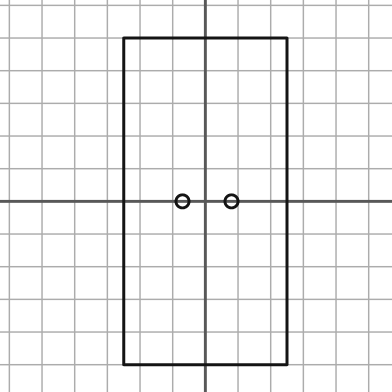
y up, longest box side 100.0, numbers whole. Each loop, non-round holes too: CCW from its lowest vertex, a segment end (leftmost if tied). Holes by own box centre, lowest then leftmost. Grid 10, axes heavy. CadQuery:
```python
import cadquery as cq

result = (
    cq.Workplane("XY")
    .moveTo(-25.0, -50.0)
    .lineTo(25.0, -50.0)
    .lineTo(25.0, 50.0)
    .lineTo(-25.0, 50.0)
    .close()
    .moveTo(-7.0, 0.0)
    .circle(2.0)
    .moveTo(8.0, 0.0)
    .circle(2.0)
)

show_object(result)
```